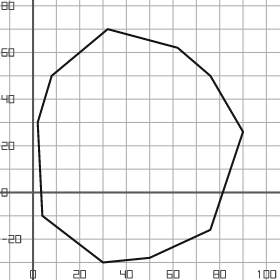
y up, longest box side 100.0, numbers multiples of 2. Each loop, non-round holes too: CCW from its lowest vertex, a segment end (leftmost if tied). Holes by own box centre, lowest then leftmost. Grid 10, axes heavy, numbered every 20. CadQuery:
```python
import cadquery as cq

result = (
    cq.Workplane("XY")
    .moveTo(30.0, -30.0)
    .lineTo(50.0, -28.0)
    .lineTo(76.0, -16.0)
    .lineTo(90.0, 26.0)
    .lineTo(76.0, 50.0)
    .lineTo(62.0, 62.0)
    .lineTo(32.0, 70.0)
    .lineTo(8.0, 50.0)
    .lineTo(2.0, 30.0)
    .lineTo(4.0, -10.0)
    .close()
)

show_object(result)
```